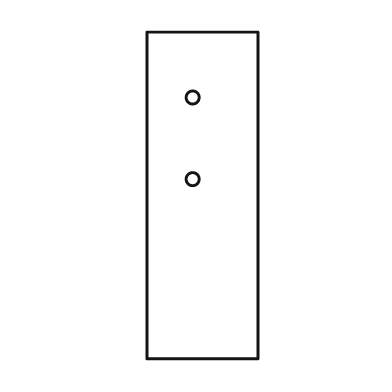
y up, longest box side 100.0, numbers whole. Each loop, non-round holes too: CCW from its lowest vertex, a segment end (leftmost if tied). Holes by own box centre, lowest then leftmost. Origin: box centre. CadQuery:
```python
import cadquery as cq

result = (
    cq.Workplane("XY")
    .moveTo(-17.0, -50.0)
    .lineTo(17.0, -50.0)
    .lineTo(17.0, 50.0)
    .lineTo(-17.0, 50.0)
    .close()
    .moveTo(-3.0, 5.0)
    .circle(2.0)
    .moveTo(-3.0, 30.0)
    .circle(2.0)
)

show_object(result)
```